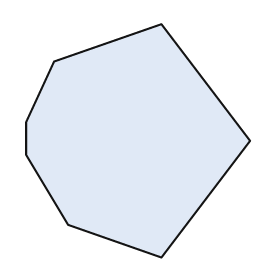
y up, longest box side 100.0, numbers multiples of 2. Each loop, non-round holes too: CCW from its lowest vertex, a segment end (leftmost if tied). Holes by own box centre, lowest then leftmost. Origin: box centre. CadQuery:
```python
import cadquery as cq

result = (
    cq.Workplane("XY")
    .moveTo(10.0, -50.0)
    .lineTo(48.0, 0.0)
    .lineTo(10.0, 50.0)
    .lineTo(-36.0, 34.0)
    .lineTo(-48.0, 8.0)
    .lineTo(-48.0, -6.0)
    .lineTo(-30.0, -36.0)
    .close()
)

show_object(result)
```